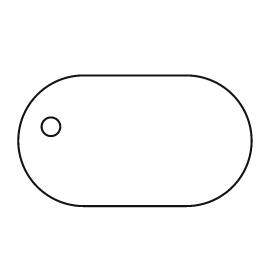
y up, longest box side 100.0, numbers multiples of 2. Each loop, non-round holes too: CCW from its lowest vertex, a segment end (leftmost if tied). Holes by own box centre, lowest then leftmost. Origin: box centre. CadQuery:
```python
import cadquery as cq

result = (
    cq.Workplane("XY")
    .moveTo(-22.0, -28.0)
    .lineTo(22.0, -28.0)
    .threePointArc((50.0, 0.0), (22.0, 28.0))
    .lineTo(-22.0, 28.0)
    .threePointArc((-50.0, 0.0), (-22.0, -28.0))
    .close()
    .moveTo(-36.0, 6.0)
    .circle(4.0)
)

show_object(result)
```